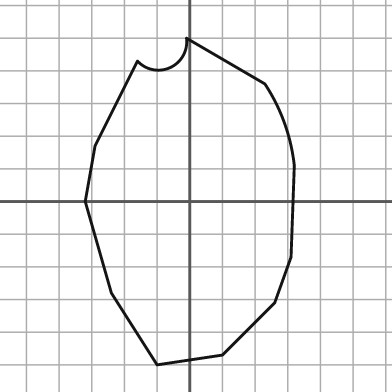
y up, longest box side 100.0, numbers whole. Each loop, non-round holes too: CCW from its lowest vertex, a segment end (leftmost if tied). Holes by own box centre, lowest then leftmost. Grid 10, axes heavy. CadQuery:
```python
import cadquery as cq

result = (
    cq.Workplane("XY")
    .moveTo(-10.0, -50.0)
    .lineTo(10.0, -47.0)
    .lineTo(26.0, -31.0)
    .lineTo(31.0, -17.0)
    .lineTo(32.0, 11.0)
    .threePointArc((29.0, 24.0), (23.0, 36.0))
    .lineTo(-1.0, 50.0)
    .threePointArc((-6.0, 41.0), (-16.0, 43.0))
    .lineTo(-29.0, 17.0)
    .lineTo(-32.0, 0.0)
    .lineTo(-24.0, -28.0)
    .close()
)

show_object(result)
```